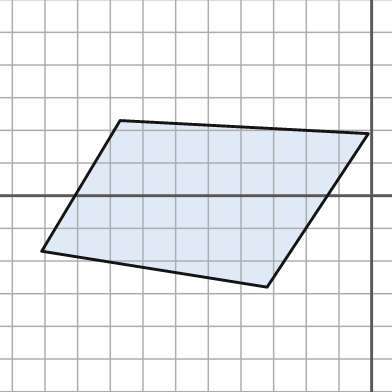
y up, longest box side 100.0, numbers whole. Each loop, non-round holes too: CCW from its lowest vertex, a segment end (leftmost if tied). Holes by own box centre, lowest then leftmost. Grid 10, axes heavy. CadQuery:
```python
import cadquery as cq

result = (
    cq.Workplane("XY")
    .moveTo(-32.0, -28.0)
    .lineTo(-1.0, 19.0)
    .lineTo(-77.0, 23.0)
    .lineTo(-101.0, -17.0)
    .close()
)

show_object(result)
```